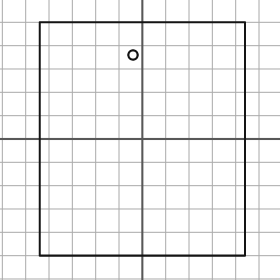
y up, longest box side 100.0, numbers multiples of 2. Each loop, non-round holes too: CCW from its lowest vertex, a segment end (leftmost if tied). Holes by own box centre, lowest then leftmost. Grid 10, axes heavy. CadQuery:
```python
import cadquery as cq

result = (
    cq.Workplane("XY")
    .moveTo(-44.0, -50.0)
    .lineTo(44.0, -50.0)
    .lineTo(44.0, 50.0)
    .lineTo(-44.0, 50.0)
    .close()
    .moveTo(-4.0, 36.0)
    .circle(2.0)
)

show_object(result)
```